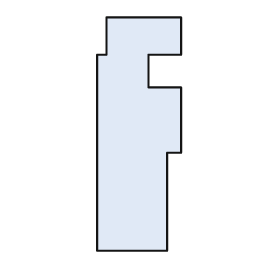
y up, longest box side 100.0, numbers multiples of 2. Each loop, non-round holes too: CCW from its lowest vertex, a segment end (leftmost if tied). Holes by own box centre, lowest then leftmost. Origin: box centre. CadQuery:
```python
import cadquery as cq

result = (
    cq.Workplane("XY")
    .moveTo(-18.0, -50.0)
    .lineTo(12.0, -50.0)
    .lineTo(12.0, -8.0)
    .lineTo(18.0, -8.0)
    .lineTo(18.0, 20.0)
    .lineTo(4.0, 20.0)
    .lineTo(4.0, 34.0)
    .lineTo(18.0, 34.0)
    .lineTo(18.0, 50.0)
    .lineTo(-14.0, 50.0)
    .lineTo(-14.0, 34.0)
    .lineTo(-18.0, 34.0)
    .close()
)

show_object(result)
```